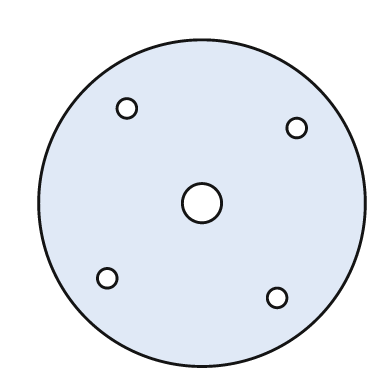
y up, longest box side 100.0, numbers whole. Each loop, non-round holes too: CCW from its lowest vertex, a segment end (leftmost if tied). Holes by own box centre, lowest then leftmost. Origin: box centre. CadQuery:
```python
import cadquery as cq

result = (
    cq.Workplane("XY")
    .moveTo(0.0, 0.0)
    .circle(50.0)
    .moveTo(23.0, -29.0)
    .circle(3.0)
    .moveTo(-29.0, -23.0)
    .circle(3.0)
    .moveTo(0.0, 0.0)
    .circle(6.0)
    .moveTo(29.0, 23.0)
    .circle(3.0)
    .moveTo(-23.0, 29.0)
    .circle(3.0)
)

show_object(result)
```